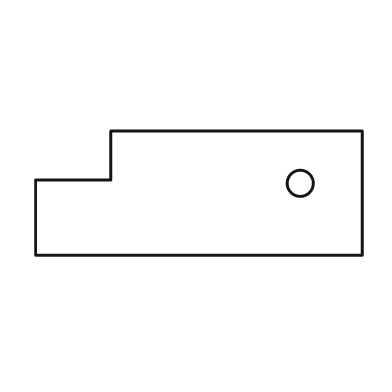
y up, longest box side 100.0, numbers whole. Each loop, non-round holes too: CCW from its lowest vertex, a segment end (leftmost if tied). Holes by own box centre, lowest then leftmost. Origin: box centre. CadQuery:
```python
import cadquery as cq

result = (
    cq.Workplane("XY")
    .moveTo(-50.0, -19.0)
    .lineTo(50.0, -19.0)
    .lineTo(50.0, 19.0)
    .lineTo(-27.0, 19.0)
    .lineTo(-27.0, 4.0)
    .lineTo(-50.0, 4.0)
    .close()
    .moveTo(31.0, 3.0)
    .circle(4.0)
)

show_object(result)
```